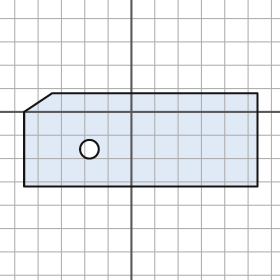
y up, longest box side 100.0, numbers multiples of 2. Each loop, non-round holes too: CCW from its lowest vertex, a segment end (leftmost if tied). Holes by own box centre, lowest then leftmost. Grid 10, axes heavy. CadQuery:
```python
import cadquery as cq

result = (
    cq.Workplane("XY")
    .moveTo(-46.0, -32.0)
    .lineTo(54.0, -32.0)
    .lineTo(54.0, 8.0)
    .lineTo(-34.0, 8.0)
    .lineTo(-46.0, 0.0)
    .close()
    .moveTo(-18.0, -16.0)
    .circle(4.0)
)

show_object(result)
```